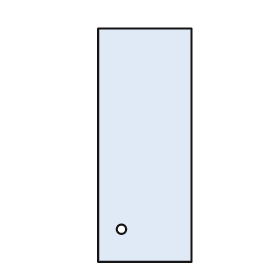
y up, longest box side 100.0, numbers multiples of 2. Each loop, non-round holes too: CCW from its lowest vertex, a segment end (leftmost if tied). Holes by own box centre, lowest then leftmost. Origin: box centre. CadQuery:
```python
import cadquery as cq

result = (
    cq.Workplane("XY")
    .moveTo(-20.0, -50.0)
    .lineTo(20.0, -50.0)
    .lineTo(20.0, 50.0)
    .lineTo(-20.0, 50.0)
    .close()
    .moveTo(-10.0, -36.0)
    .circle(2.0)
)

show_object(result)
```